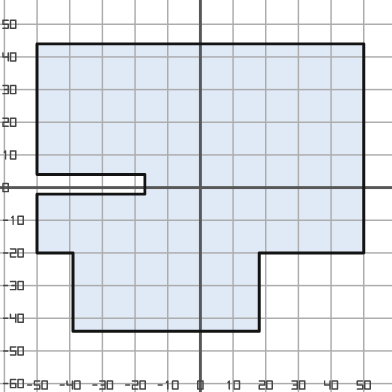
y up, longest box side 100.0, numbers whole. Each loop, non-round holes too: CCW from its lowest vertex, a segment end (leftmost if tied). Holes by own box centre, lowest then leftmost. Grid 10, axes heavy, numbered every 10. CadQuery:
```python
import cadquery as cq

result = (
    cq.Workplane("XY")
    .moveTo(-39.0, -44.0)
    .lineTo(18.0, -44.0)
    .lineTo(18.0, -20.0)
    .lineTo(50.0, -20.0)
    .lineTo(50.0, 44.0)
    .lineTo(-50.0, 44.0)
    .lineTo(-50.0, 4.0)
    .lineTo(-17.0, 4.0)
    .lineTo(-17.0, -2.0)
    .lineTo(-50.0, -2.0)
    .lineTo(-50.0, -20.0)
    .lineTo(-39.0, -20.0)
    .close()
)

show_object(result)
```